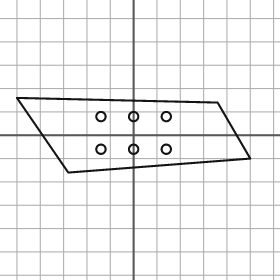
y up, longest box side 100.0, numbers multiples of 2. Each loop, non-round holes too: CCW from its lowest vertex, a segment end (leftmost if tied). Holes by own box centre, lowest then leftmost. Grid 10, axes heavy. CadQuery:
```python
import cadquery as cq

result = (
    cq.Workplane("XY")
    .moveTo(-28.0, -16.0)
    .lineTo(50.0, -10.0)
    .lineTo(36.0, 14.0)
    .lineTo(-50.0, 16.0)
    .close()
    .moveTo(-14.0, -6.0)
    .circle(2.0)
    .moveTo(0.0, -6.0)
    .circle(2.0)
    .moveTo(14.0, -6.0)
    .circle(2.0)
    .moveTo(-14.0, 8.0)
    .circle(2.0)
    .moveTo(0.0, 8.0)
    .circle(2.0)
    .moveTo(14.0, 8.0)
    .circle(2.0)
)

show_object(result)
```